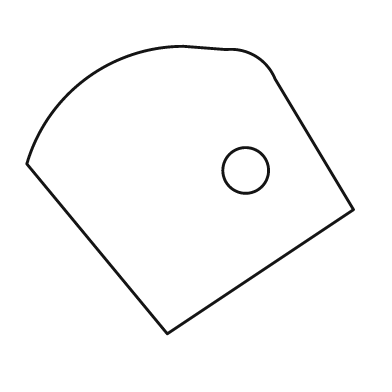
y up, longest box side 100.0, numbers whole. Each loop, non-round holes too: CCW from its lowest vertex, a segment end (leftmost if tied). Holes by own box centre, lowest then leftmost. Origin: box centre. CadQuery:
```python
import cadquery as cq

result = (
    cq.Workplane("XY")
    .moveTo(-7.0, -44.0)
    .lineTo(50.0, -6.0)
    .lineTo(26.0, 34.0)
    .threePointArc((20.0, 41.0), (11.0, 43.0))
    .lineTo(-2.0, 44.0)
    .threePointArc((-32.0, 34.0), (-50.0, 8.0))
    .close()
    .moveTo(17.0, 6.0)
    .circle(7.0)
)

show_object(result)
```